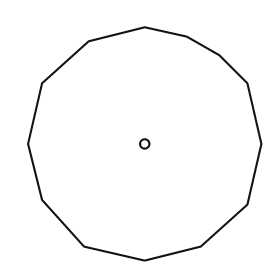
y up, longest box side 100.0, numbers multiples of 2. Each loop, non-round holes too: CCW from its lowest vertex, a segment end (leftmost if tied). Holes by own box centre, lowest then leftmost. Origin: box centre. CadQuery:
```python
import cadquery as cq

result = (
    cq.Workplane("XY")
    .moveTo(0.0, -50.0)
    .lineTo(24.0, -44.0)
    .lineTo(44.0, -26.0)
    .lineTo(50.0, 0.0)
    .lineTo(44.0, 26.0)
    .lineTo(32.0, 38.0)
    .lineTo(18.0, 46.0)
    .lineTo(0.0, 50.0)
    .lineTo(-24.0, 44.0)
    .lineTo(-44.0, 26.0)
    .lineTo(-50.0, 0.0)
    .lineTo(-44.0, -24.0)
    .lineTo(-26.0, -44.0)
    .close()
    .moveTo(0.0, 0.0)
    .circle(2.0)
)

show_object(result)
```